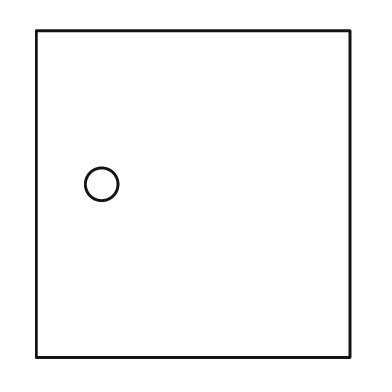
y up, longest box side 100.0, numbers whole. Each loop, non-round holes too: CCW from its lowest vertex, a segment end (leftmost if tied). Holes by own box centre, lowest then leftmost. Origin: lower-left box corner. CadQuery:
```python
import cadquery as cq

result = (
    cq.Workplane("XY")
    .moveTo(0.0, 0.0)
    .lineTo(96.0, 0.0)
    .lineTo(96.0, 100.0)
    .lineTo(0.0, 100.0)
    .close()
    .moveTo(20.0, 53.0)
    .circle(5.0)
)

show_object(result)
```